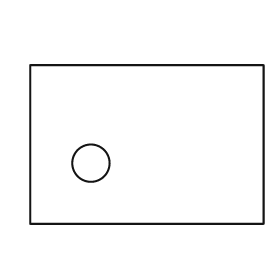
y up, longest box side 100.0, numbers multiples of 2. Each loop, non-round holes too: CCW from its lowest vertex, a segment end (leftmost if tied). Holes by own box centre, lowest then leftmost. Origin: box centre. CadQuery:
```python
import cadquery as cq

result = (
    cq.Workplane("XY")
    .moveTo(-50.0, -34.0)
    .lineTo(50.0, -34.0)
    .lineTo(50.0, 34.0)
    .lineTo(-50.0, 34.0)
    .close()
    .moveTo(-24.0, -8.0)
    .circle(8.0)
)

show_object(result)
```